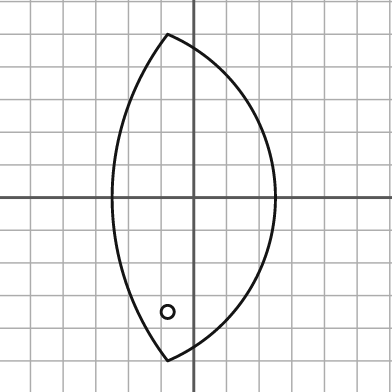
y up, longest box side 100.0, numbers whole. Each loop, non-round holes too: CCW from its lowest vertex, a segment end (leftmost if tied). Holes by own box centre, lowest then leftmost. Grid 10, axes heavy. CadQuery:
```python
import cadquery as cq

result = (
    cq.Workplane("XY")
    .moveTo(-8.0, -50.0)
    .threePointArc((25.0, 0.0), (-8.0, 50.0))
    .threePointArc((-25.0, 0.0), (-8.0, -50.0))
    .close()
    .moveTo(-8.0, -35.0)
    .circle(2.0)
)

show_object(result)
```